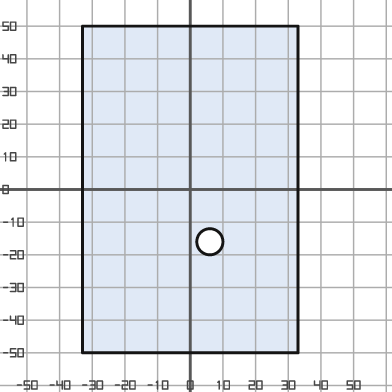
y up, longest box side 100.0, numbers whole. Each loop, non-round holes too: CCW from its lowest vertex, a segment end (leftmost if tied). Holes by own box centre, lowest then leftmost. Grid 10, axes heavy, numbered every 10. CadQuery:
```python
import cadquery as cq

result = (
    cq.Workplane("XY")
    .moveTo(-33.0, -50.0)
    .lineTo(33.0, -50.0)
    .lineTo(33.0, 50.0)
    .lineTo(-33.0, 50.0)
    .close()
    .moveTo(6.0, -16.0)
    .circle(4.0)
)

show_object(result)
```